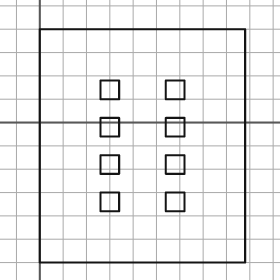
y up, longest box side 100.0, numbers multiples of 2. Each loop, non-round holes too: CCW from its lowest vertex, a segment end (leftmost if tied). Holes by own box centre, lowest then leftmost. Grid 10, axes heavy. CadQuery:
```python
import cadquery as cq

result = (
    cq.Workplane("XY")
    .moveTo(0.0, -60.0)
    .lineTo(88.0, -60.0)
    .lineTo(88.0, 40.0)
    .lineTo(0.0, 40.0)
    .close()
    .moveTo(26.0, -38.0)
    .lineTo(34.0, -38.0)
    .lineTo(34.0, -30.0)
    .lineTo(26.0, -30.0)
    .close()
    .moveTo(54.0, -38.0)
    .lineTo(62.0, -38.0)
    .lineTo(62.0, -30.0)
    .lineTo(54.0, -30.0)
    .close()
    .moveTo(26.0, -22.0)
    .lineTo(34.0, -22.0)
    .lineTo(34.0, -14.0)
    .lineTo(26.0, -14.0)
    .close()
    .moveTo(54.0, -22.0)
    .lineTo(62.0, -22.0)
    .lineTo(62.0, -14.0)
    .lineTo(54.0, -14.0)
    .close()
    .moveTo(26.0, -6.0)
    .lineTo(34.0, -6.0)
    .lineTo(34.0, 2.0)
    .lineTo(26.0, 2.0)
    .close()
    .moveTo(54.0, -6.0)
    .lineTo(62.0, -6.0)
    .lineTo(62.0, 2.0)
    .lineTo(54.0, 2.0)
    .close()
    .moveTo(26.0, 10.0)
    .lineTo(34.0, 10.0)
    .lineTo(34.0, 18.0)
    .lineTo(26.0, 18.0)
    .close()
    .moveTo(54.0, 10.0)
    .lineTo(62.0, 10.0)
    .lineTo(62.0, 18.0)
    .lineTo(54.0, 18.0)
    .close()
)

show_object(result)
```